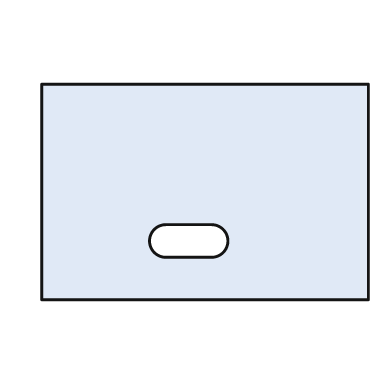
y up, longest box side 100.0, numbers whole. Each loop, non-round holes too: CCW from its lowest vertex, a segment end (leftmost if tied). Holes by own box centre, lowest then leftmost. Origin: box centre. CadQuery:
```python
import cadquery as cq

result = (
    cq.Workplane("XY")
    .moveTo(-50.0, -33.0)
    .lineTo(50.0, -33.0)
    .lineTo(50.0, 33.0)
    .lineTo(-50.0, 33.0)
    .close()
    .moveTo(-12.0, -20.0)
    .lineTo(2.0, -20.0)
    .threePointArc((7.0, -15.0), (2.0, -10.0))
    .lineTo(-12.0, -10.0)
    .threePointArc((-17.0, -15.0), (-12.0, -20.0))
    .close()
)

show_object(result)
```